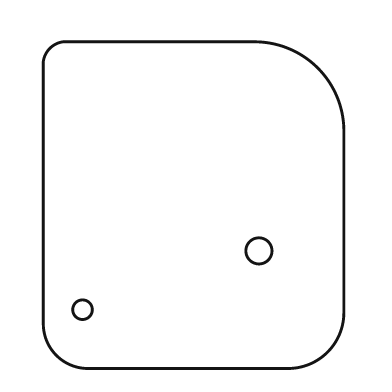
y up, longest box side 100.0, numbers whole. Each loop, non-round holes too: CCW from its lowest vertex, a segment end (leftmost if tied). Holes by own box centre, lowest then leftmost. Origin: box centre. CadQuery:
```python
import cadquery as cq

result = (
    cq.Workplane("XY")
    .moveTo(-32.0, -50.0)
    .lineTo(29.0, -50.0)
    .threePointArc((41.0, -45.0), (46.0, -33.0))
    .lineTo(46.0, 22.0)
    .threePointArc((38.0, 42.0), (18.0, 50.0))
    .lineTo(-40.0, 50.0)
    .threePointArc((-44.0, 48.0), (-46.0, 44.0))
    .lineTo(-46.0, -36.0)
    .threePointArc((-42.0, -46.0), (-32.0, -50.0))
    .close()
    .moveTo(-34.0, -32.0)
    .circle(3.0)
    .moveTo(20.0, -14.0)
    .circle(4.0)
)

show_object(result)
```